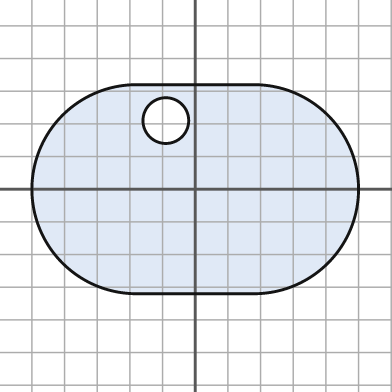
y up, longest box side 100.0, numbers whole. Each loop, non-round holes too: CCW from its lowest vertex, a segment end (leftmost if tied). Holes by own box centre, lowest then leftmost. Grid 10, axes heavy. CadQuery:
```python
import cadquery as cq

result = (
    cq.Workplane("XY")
    .moveTo(-18.0, -32.0)
    .lineTo(18.0, -32.0)
    .threePointArc((50.0, 0.0), (18.0, 32.0))
    .lineTo(-18.0, 32.0)
    .threePointArc((-50.0, 0.0), (-18.0, -32.0))
    .close()
    .moveTo(-9.0, 21.0)
    .circle(7.0)
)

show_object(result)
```